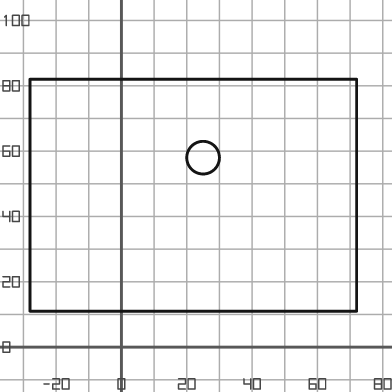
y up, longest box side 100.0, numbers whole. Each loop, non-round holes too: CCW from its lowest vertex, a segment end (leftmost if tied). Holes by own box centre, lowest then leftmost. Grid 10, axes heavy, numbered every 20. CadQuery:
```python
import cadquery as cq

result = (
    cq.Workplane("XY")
    .moveTo(-28.0, 11.0)
    .lineTo(72.0, 11.0)
    .lineTo(72.0, 82.0)
    .lineTo(-28.0, 82.0)
    .close()
    .moveTo(25.0, 58.0)
    .circle(5.0)
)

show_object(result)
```